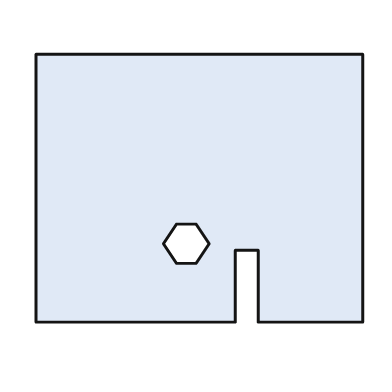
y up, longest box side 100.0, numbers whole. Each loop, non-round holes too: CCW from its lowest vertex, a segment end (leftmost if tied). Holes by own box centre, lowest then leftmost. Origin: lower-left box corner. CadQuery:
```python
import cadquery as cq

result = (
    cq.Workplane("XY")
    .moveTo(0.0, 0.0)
    .lineTo(61.0, 0.0)
    .lineTo(61.0, 22.0)
    .lineTo(68.0, 22.0)
    .lineTo(68.0, 0.0)
    .lineTo(100.0, 0.0)
    .lineTo(100.0, 82.0)
    .lineTo(0.0, 82.0)
    .close()
    .moveTo(43.0, 18.0)
    .lineTo(49.0, 18.0)
    .lineTo(53.0, 24.0)
    .lineTo(49.0, 30.0)
    .lineTo(43.0, 30.0)
    .lineTo(39.0, 24.0)
    .close()
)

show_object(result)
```